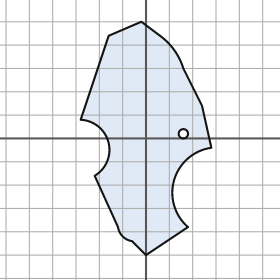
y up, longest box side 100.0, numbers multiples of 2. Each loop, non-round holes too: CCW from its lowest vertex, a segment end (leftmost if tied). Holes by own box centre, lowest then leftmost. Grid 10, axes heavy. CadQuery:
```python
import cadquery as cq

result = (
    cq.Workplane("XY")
    .moveTo(0.0, -50.0)
    .lineTo(18.0, -38.0)
    .threePointArc((12.0, -18.0), (28.0, -4.0))
    .lineTo(24.0, 14.0)
    .lineTo(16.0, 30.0)
    .threePointArc((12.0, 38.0), (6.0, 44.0))
    .lineTo(-2.0, 50.0)
    .lineTo(-16.0, 44.0)
    .lineTo(-28.0, 8.0)
    .threePointArc((-16.0, -2.0), (-22.0, -16.0))
    .lineTo(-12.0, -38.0)
    .threePointArc((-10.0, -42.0), (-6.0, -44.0))
    .close()
    .moveTo(16.0, 2.0)
    .circle(2.0)
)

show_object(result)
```